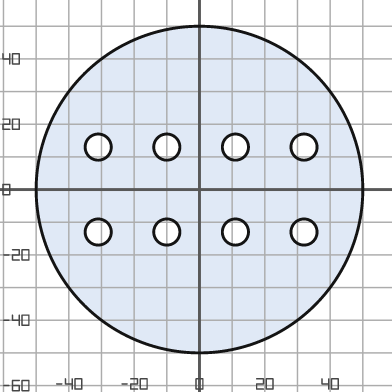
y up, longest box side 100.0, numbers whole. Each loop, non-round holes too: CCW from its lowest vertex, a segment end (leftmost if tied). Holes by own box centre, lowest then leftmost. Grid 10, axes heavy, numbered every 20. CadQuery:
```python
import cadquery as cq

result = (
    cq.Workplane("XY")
    .moveTo(0.0, 0.0)
    .circle(50.0)
    .moveTo(-31.0, -13.0)
    .circle(4.0)
    .moveTo(-10.0, -13.0)
    .circle(4.0)
    .moveTo(11.0, -13.0)
    .circle(4.0)
    .moveTo(32.0, -13.0)
    .circle(4.0)
    .moveTo(-31.0, 13.0)
    .circle(4.0)
    .moveTo(-10.0, 13.0)
    .circle(4.0)
    .moveTo(11.0, 13.0)
    .circle(4.0)
    .moveTo(32.0, 13.0)
    .circle(4.0)
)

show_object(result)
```